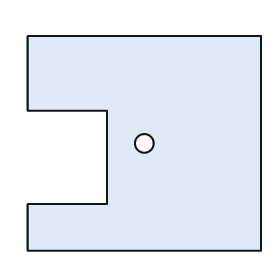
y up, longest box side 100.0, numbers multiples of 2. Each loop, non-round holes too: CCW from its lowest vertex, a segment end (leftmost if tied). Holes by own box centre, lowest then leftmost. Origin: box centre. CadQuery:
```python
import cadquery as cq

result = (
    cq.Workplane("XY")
    .moveTo(-50.0, -46.0)
    .lineTo(50.0, -46.0)
    .lineTo(50.0, 46.0)
    .lineTo(-50.0, 46.0)
    .lineTo(-50.0, 14.0)
    .lineTo(-16.0, 14.0)
    .lineTo(-16.0, -26.0)
    .lineTo(-50.0, -26.0)
    .close()
    .moveTo(0.0, 0.0)
    .circle(4.0)
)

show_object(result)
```